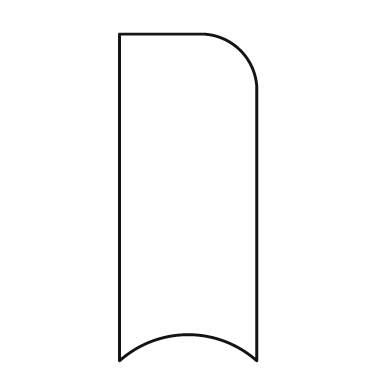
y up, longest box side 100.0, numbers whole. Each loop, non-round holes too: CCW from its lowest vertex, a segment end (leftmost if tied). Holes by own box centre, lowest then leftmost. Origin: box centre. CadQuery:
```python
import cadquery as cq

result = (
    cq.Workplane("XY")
    .moveTo(-21.0, -50.0)
    .threePointArc((0.0, -42.0), (21.0, -50.0))
    .lineTo(21.0, 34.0)
    .threePointArc((16.0, 45.0), (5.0, 50.0))
    .lineTo(-21.0, 50.0)
    .close()
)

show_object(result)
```